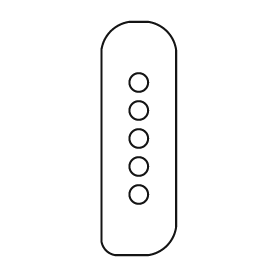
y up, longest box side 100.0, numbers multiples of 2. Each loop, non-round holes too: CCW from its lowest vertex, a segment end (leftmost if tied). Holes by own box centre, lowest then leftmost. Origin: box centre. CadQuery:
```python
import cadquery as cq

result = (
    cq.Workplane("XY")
    .moveTo(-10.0, -50.0)
    .lineTo(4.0, -50.0)
    .threePointArc((12.0, -46.0), (16.0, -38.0))
    .lineTo(16.0, 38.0)
    .threePointArc((12.0, 46.0), (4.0, 50.0))
    .lineTo(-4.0, 50.0)
    .threePointArc((-12.0, 46.0), (-16.0, 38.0))
    .lineTo(-16.0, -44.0)
    .threePointArc((-14.0, -48.0), (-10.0, -50.0))
    .close()
    .moveTo(0.0, -24.0)
    .circle(4.0)
    .moveTo(0.0, -12.0)
    .circle(4.0)
    .moveTo(0.0, 0.0)
    .circle(4.0)
    .moveTo(0.0, 12.0)
    .circle(4.0)
    .moveTo(0.0, 24.0)
    .circle(4.0)
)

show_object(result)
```